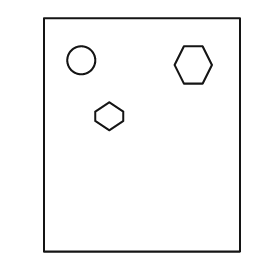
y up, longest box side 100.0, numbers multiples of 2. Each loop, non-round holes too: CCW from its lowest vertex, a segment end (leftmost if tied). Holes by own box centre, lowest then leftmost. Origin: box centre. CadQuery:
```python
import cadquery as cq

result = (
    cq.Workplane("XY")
    .moveTo(-42.0, -50.0)
    .lineTo(42.0, -50.0)
    .lineTo(42.0, 50.0)
    .lineTo(-42.0, 50.0)
    .close()
    .moveTo(-14.0, 2.0)
    .lineTo(-8.0, 6.0)
    .lineTo(-8.0, 10.0)
    .lineTo(-14.0, 14.0)
    .lineTo(-20.0, 10.0)
    .lineTo(-20.0, 6.0)
    .close()
    .moveTo(18.0, 22.0)
    .lineTo(26.0, 22.0)
    .lineTo(30.0, 30.0)
    .lineTo(26.0, 38.0)
    .lineTo(18.0, 38.0)
    .lineTo(14.0, 30.0)
    .close()
    .moveTo(-26.0, 32.0)
    .circle(6.0)
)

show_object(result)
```